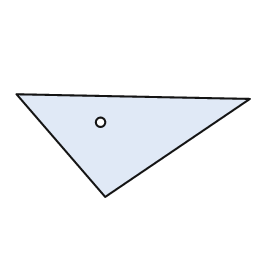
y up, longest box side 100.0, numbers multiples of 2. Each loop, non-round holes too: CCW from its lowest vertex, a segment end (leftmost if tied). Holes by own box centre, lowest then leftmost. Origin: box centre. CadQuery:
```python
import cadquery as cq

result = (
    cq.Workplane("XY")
    .moveTo(-12.0, -22.0)
    .lineTo(50.0, 20.0)
    .lineTo(-50.0, 22.0)
    .close()
    .moveTo(-14.0, 10.0)
    .circle(2.0)
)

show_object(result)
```